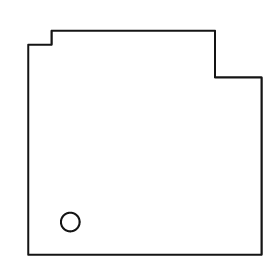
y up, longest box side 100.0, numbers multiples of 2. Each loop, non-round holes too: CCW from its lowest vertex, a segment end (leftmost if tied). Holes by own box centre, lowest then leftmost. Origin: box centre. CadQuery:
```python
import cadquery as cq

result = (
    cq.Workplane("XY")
    .moveTo(-50.0, -48.0)
    .lineTo(50.0, -48.0)
    .lineTo(50.0, 28.0)
    .lineTo(30.0, 28.0)
    .lineTo(30.0, 48.0)
    .lineTo(-40.0, 48.0)
    .lineTo(-40.0, 42.0)
    .lineTo(-50.0, 42.0)
    .close()
    .moveTo(-32.0, -34.0)
    .circle(4.0)
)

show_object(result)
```